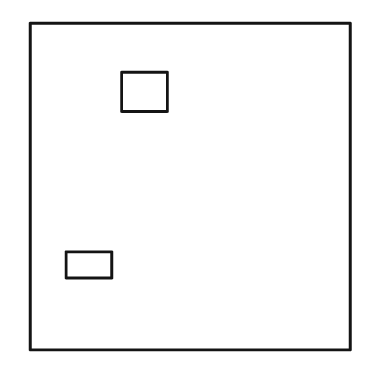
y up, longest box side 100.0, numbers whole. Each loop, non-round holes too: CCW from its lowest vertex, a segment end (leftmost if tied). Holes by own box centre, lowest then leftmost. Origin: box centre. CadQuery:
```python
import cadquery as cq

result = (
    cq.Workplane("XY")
    .moveTo(-49.0, -50.0)
    .lineTo(49.0, -50.0)
    .lineTo(49.0, 50.0)
    .lineTo(-49.0, 50.0)
    .close()
    .moveTo(-38.0, -28.0)
    .lineTo(-24.0, -28.0)
    .lineTo(-24.0, -20.0)
    .lineTo(-38.0, -20.0)
    .close()
    .moveTo(-21.0, 23.0)
    .lineTo(-7.0, 23.0)
    .lineTo(-7.0, 35.0)
    .lineTo(-21.0, 35.0)
    .close()
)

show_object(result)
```